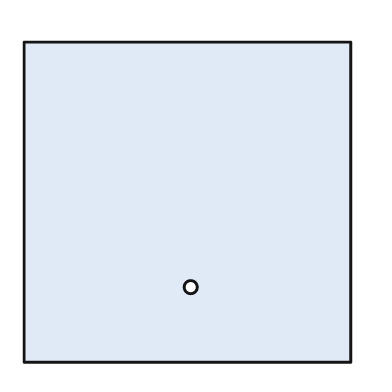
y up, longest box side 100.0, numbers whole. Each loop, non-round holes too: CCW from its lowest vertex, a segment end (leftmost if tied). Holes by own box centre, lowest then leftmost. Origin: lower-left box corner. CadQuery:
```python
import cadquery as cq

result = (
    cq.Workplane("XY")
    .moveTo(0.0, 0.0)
    .lineTo(100.0, 0.0)
    .lineTo(100.0, 98.0)
    .lineTo(0.0, 98.0)
    .close()
    .moveTo(51.0, 23.0)
    .circle(2.0)
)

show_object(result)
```